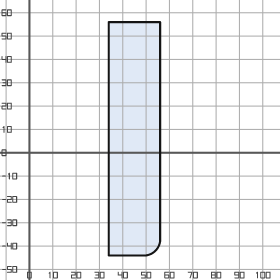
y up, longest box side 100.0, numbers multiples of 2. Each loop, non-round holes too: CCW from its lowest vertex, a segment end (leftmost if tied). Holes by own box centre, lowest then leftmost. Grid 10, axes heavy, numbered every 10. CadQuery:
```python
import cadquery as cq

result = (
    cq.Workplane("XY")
    .moveTo(34.0, -44.0)
    .lineTo(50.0, -44.0)
    .threePointArc((54.0, -42.0), (56.0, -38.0))
    .lineTo(56.0, 56.0)
    .lineTo(34.0, 56.0)
    .close()
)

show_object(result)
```